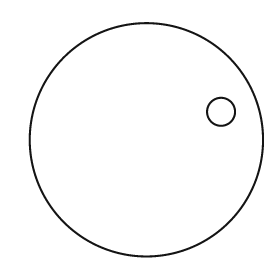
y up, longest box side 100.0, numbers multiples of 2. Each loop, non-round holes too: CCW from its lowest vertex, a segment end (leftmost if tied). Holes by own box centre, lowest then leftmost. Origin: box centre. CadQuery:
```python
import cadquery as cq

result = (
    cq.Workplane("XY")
    .moveTo(0.0, 0.0)
    .circle(50.0)
    .moveTo(32.0, 12.0)
    .circle(6.0)
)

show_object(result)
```